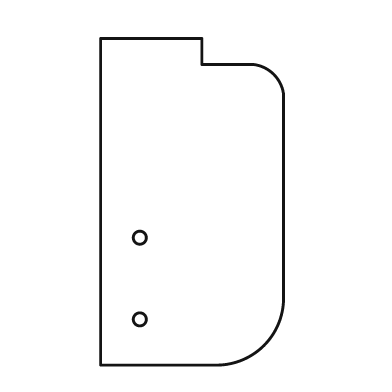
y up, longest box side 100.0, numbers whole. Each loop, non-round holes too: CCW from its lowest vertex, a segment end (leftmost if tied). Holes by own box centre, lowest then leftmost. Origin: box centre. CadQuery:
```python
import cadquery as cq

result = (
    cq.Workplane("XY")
    .moveTo(-28.0, -50.0)
    .lineTo(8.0, -50.0)
    .threePointArc((22.0, -44.0), (28.0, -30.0))
    .lineTo(28.0, 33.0)
    .threePointArc((25.0, 39.0), (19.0, 42.0))
    .lineTo(3.0, 42.0)
    .lineTo(3.0, 50.0)
    .lineTo(-28.0, 50.0)
    .close()
    .moveTo(-16.0, -36.0)
    .circle(2.0)
    .moveTo(-16.0, -11.0)
    .circle(2.0)
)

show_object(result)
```